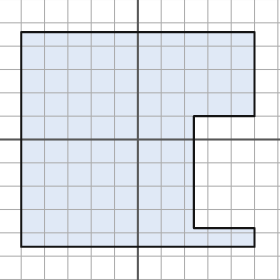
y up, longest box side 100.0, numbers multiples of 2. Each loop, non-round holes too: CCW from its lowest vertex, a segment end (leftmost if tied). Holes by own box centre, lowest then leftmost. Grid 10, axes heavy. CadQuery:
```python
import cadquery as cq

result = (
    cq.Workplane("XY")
    .moveTo(-50.0, -46.0)
    .lineTo(50.0, -46.0)
    .lineTo(50.0, -38.0)
    .lineTo(24.0, -38.0)
    .lineTo(24.0, 10.0)
    .lineTo(50.0, 10.0)
    .lineTo(50.0, 46.0)
    .lineTo(-50.0, 46.0)
    .close()
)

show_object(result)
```